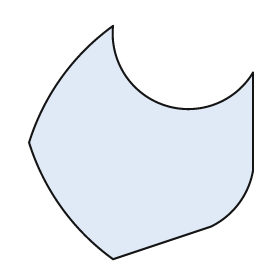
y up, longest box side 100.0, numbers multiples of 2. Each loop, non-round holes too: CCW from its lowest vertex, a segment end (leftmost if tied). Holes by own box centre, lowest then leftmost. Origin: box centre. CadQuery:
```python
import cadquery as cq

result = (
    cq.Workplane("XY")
    .moveTo(-12.0, -50.0)
    .lineTo(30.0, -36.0)
    .threePointArc((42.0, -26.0), (48.0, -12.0))
    .lineTo(48.0, 30.0)
    .threePointArc((10.0, 16.0), (-12.0, 50.0))
    .threePointArc((-34.0, 28.0), (-48.0, 0.0))
    .threePointArc((-34.0, -28.0), (-12.0, -50.0))
    .close()
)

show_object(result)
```